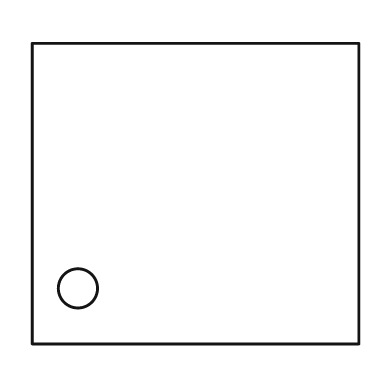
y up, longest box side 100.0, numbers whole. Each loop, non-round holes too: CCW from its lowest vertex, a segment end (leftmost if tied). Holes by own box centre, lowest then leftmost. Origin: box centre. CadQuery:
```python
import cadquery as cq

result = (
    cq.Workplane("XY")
    .moveTo(-50.0, -46.0)
    .lineTo(50.0, -46.0)
    .lineTo(50.0, 46.0)
    .lineTo(-50.0, 46.0)
    .close()
    .moveTo(-36.0, -29.0)
    .circle(6.0)
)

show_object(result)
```